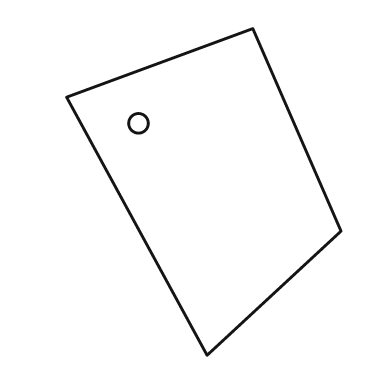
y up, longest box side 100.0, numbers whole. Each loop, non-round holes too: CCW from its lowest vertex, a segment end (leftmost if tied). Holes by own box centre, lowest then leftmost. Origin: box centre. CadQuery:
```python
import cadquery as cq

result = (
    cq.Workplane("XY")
    .moveTo(1.0, -50.0)
    .lineTo(42.0, -12.0)
    .lineTo(15.0, 50.0)
    .lineTo(-42.0, 29.0)
    .close()
    .moveTo(-20.0, 21.0)
    .circle(3.0)
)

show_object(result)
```